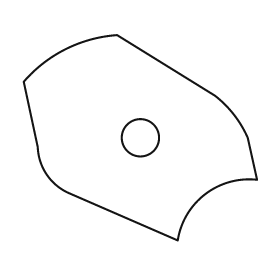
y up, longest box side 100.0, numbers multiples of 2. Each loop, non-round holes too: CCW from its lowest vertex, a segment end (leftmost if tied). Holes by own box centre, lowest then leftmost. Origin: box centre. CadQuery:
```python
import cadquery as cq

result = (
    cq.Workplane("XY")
    .moveTo(16.0, -44.0)
    .threePointArc((28.0, -24.0), (50.0, -18.0))
    .lineTo(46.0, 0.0)
    .threePointArc((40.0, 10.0), (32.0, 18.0))
    .lineTo(-10.0, 44.0)
    .threePointArc((-32.0, 38.0), (-50.0, 24.0))
    .lineTo(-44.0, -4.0)
    .threePointArc((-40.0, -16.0), (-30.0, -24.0))
    .close()
    .moveTo(0.0, 0.0)
    .circle(8.0)
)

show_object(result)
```